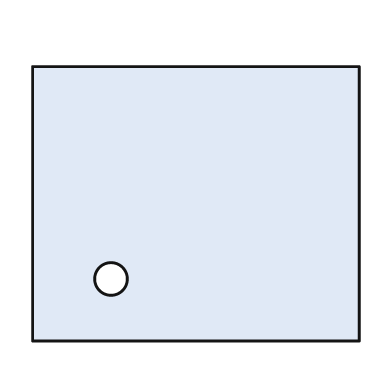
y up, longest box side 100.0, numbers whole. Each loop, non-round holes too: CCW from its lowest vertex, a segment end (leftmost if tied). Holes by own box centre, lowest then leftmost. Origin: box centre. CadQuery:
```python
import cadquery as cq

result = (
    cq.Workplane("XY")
    .moveTo(-50.0, -42.0)
    .lineTo(50.0, -42.0)
    .lineTo(50.0, 42.0)
    .lineTo(-50.0, 42.0)
    .close()
    .moveTo(-26.0, -23.0)
    .circle(5.0)
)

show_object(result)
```